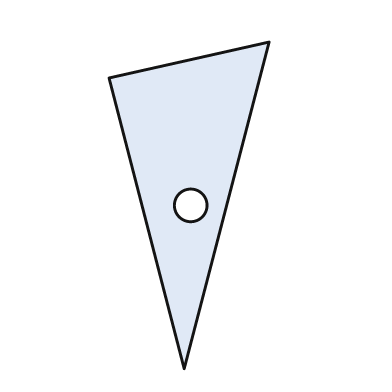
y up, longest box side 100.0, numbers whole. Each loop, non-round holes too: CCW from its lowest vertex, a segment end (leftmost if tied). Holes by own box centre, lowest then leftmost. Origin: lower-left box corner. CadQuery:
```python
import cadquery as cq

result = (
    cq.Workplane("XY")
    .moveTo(23.0, 0.0)
    .lineTo(49.0, 100.0)
    .lineTo(0.0, 89.0)
    .close()
    .moveTo(25.0, 50.0)
    .circle(5.0)
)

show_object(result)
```